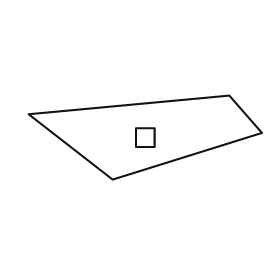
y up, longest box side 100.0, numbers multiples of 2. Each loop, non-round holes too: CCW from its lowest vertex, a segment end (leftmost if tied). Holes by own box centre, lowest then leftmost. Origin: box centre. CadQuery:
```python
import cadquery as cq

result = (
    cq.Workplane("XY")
    .moveTo(-14.0, -18.0)
    .lineTo(50.0, 2.0)
    .lineTo(36.0, 18.0)
    .lineTo(-50.0, 10.0)
    .close()
    .moveTo(-4.0, -4.0)
    .lineTo(4.0, -4.0)
    .lineTo(4.0, 4.0)
    .lineTo(-4.0, 4.0)
    .close()
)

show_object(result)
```